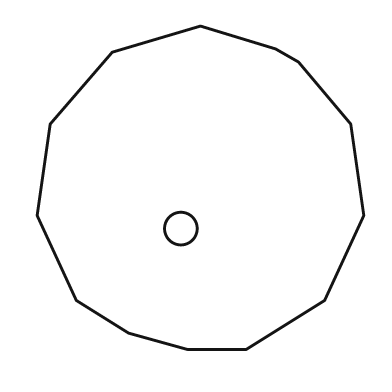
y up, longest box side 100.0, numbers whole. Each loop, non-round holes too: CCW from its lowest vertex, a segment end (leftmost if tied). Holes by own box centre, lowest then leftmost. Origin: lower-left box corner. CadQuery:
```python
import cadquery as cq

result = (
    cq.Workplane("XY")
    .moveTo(46.0, 0.0)
    .lineTo(64.0, 0.0)
    .lineTo(88.0, 15.0)
    .lineTo(100.0, 41.0)
    .lineTo(96.0, 69.0)
    .lineTo(80.0, 88.0)
    .lineTo(73.0, 92.0)
    .lineTo(50.0, 99.0)
    .lineTo(23.0, 91.0)
    .lineTo(4.0, 69.0)
    .lineTo(0.0, 41.0)
    .lineTo(12.0, 15.0)
    .lineTo(28.0, 5.0)
    .close()
    .moveTo(44.0, 37.0)
    .circle(5.0)
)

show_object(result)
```